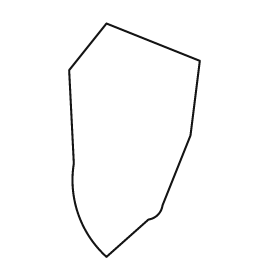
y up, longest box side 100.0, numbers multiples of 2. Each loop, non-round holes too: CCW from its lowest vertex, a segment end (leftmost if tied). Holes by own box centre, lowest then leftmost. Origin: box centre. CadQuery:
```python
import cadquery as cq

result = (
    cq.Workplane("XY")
    .moveTo(-12.0, -50.0)
    .lineTo(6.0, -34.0)
    .threePointArc((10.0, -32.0), (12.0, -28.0))
    .lineTo(24.0, 2.0)
    .lineTo(28.0, 34.0)
    .lineTo(-12.0, 50.0)
    .lineTo(-28.0, 30.0)
    .lineTo(-26.0, -10.0)
    .threePointArc((-24.0, -32.0), (-12.0, -50.0))
    .close()
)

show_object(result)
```